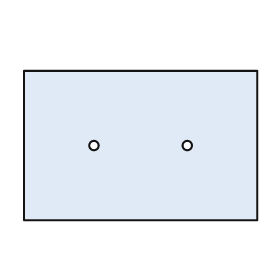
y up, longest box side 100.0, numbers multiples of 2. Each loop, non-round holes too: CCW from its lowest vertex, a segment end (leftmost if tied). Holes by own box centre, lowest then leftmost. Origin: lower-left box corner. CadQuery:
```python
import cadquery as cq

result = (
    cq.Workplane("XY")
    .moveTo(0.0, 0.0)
    .lineTo(100.0, 0.0)
    .lineTo(100.0, 64.0)
    .lineTo(0.0, 64.0)
    .close()
    .moveTo(30.0, 32.0)
    .circle(2.0)
    .moveTo(70.0, 32.0)
    .circle(2.0)
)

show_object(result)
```